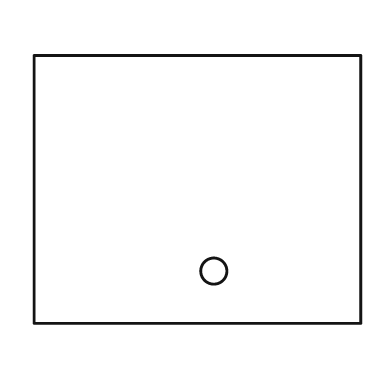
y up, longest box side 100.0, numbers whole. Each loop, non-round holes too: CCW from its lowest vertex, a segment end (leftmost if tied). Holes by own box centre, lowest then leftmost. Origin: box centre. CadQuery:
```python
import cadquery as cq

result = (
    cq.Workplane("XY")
    .moveTo(-50.0, -41.0)
    .lineTo(50.0, -41.0)
    .lineTo(50.0, 41.0)
    .lineTo(-50.0, 41.0)
    .close()
    .moveTo(5.0, -25.0)
    .circle(4.0)
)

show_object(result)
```